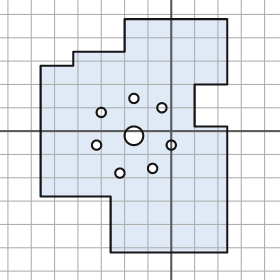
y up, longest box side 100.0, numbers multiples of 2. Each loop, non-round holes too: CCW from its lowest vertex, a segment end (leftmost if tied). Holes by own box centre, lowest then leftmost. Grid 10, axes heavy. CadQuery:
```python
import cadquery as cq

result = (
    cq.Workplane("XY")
    .moveTo(-26.0, -52.0)
    .lineTo(24.0, -52.0)
    .lineTo(24.0, 2.0)
    .lineTo(10.0, 2.0)
    .lineTo(10.0, 20.0)
    .lineTo(24.0, 20.0)
    .lineTo(24.0, 48.0)
    .lineTo(-20.0, 48.0)
    .lineTo(-20.0, 34.0)
    .lineTo(-42.0, 34.0)
    .lineTo(-42.0, 28.0)
    .lineTo(-56.0, 28.0)
    .lineTo(-56.0, -28.0)
    .lineTo(-26.0, -28.0)
    .close()
    .moveTo(-22.0, -18.0)
    .circle(2.0)
    .moveTo(-8.0, -16.0)
    .circle(2.0)
    .moveTo(-32.0, -6.0)
    .circle(2.0)
    .moveTo(0.0, -6.0)
    .circle(2.0)
    .moveTo(-16.0, -2.0)
    .circle(4.0)
    .moveTo(-30.0, 8.0)
    .circle(2.0)
    .moveTo(-4.0, 10.0)
    .circle(2.0)
    .moveTo(-16.0, 14.0)
    .circle(2.0)
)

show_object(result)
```